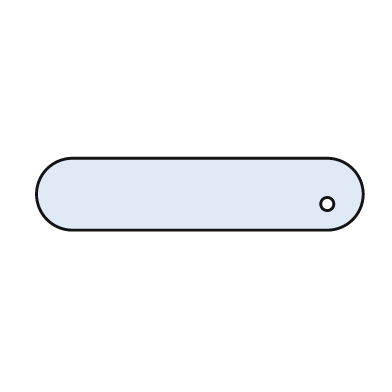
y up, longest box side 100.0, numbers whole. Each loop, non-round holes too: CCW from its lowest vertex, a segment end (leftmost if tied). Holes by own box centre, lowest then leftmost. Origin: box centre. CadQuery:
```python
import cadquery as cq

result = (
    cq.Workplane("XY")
    .moveTo(-39.0, -11.0)
    .lineTo(39.0, -11.0)
    .threePointArc((50.0, 0.0), (39.0, 11.0))
    .lineTo(-39.0, 11.0)
    .threePointArc((-50.0, 0.0), (-39.0, -11.0))
    .close()
    .moveTo(39.0, -3.0)
    .circle(2.0)
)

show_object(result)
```